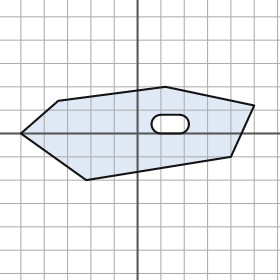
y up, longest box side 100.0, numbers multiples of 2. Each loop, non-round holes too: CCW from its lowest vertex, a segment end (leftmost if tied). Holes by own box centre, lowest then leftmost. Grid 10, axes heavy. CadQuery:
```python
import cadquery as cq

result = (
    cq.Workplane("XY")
    .moveTo(-22.0, -20.0)
    .lineTo(40.0, -10.0)
    .lineTo(50.0, 12.0)
    .lineTo(12.0, 20.0)
    .lineTo(-34.0, 14.0)
    .lineTo(-50.0, 0.0)
    .close()
    .moveTo(10.0, 0.0)
    .lineTo(18.0, 0.0)
    .threePointArc((22.0, 4.0), (18.0, 8.0))
    .lineTo(10.0, 8.0)
    .threePointArc((6.0, 4.0), (10.0, 0.0))
    .close()
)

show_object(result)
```